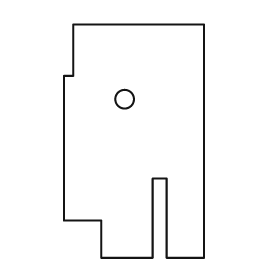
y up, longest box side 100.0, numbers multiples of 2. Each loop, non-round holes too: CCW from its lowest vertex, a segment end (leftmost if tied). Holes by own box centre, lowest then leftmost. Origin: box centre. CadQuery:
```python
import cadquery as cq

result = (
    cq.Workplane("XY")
    .moveTo(-14.0, -50.0)
    .lineTo(8.0, -50.0)
    .lineTo(8.0, -16.0)
    .lineTo(14.0, -16.0)
    .lineTo(14.0, -50.0)
    .lineTo(30.0, -50.0)
    .lineTo(30.0, 50.0)
    .lineTo(-26.0, 50.0)
    .lineTo(-26.0, 28.0)
    .lineTo(-30.0, 28.0)
    .lineTo(-30.0, -34.0)
    .lineTo(-14.0, -34.0)
    .close()
    .moveTo(-4.0, 18.0)
    .circle(4.0)
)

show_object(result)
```